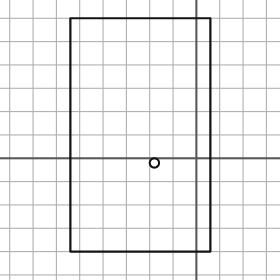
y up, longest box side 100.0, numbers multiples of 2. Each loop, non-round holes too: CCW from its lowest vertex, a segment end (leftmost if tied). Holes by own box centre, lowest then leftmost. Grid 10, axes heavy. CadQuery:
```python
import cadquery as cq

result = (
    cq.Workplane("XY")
    .moveTo(-54.0, -40.0)
    .lineTo(6.0, -40.0)
    .lineTo(6.0, 60.0)
    .lineTo(-54.0, 60.0)
    .close()
    .moveTo(-18.0, -2.0)
    .circle(2.0)
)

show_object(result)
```